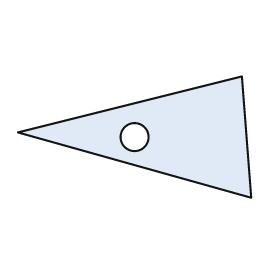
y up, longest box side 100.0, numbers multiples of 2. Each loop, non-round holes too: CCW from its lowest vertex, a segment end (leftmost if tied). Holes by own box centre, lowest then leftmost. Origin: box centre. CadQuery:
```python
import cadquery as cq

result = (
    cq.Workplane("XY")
    .moveTo(50.0, -26.0)
    .lineTo(46.0, 26.0)
    .lineTo(-50.0, 2.0)
    .close()
    .moveTo(0.0, 0.0)
    .circle(6.0)
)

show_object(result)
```